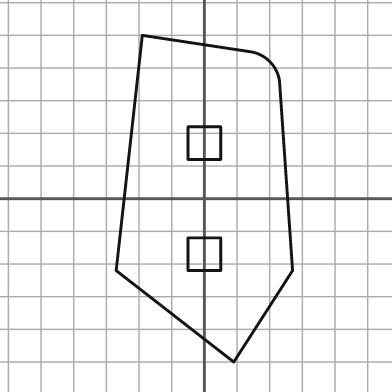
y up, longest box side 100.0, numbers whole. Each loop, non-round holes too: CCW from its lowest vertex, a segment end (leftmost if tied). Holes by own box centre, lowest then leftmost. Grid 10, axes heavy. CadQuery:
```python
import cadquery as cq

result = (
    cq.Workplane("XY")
    .moveTo(9.0, -50.0)
    .lineTo(27.0, -22.0)
    .lineTo(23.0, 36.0)
    .threePointArc((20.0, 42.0), (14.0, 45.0))
    .lineTo(-19.0, 50.0)
    .lineTo(-27.0, -22.0)
    .close()
    .moveTo(-5.0, -22.0)
    .lineTo(5.0, -22.0)
    .lineTo(5.0, -12.0)
    .lineTo(-5.0, -12.0)
    .close()
    .moveTo(-5.0, 12.0)
    .lineTo(5.0, 12.0)
    .lineTo(5.0, 22.0)
    .lineTo(-5.0, 22.0)
    .close()
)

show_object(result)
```